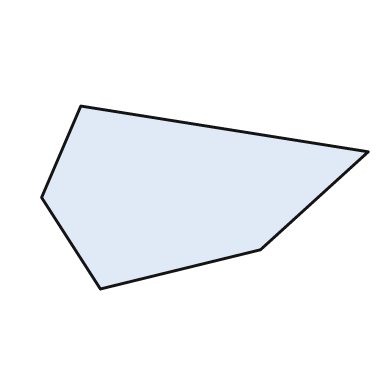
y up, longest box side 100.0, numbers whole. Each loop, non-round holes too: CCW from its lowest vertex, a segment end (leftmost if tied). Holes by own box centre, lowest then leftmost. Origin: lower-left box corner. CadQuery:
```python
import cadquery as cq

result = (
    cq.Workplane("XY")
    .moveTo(18.0, 0.0)
    .lineTo(67.0, 12.0)
    .lineTo(100.0, 42.0)
    .lineTo(12.0, 56.0)
    .lineTo(0.0, 28.0)
    .close()
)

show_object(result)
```